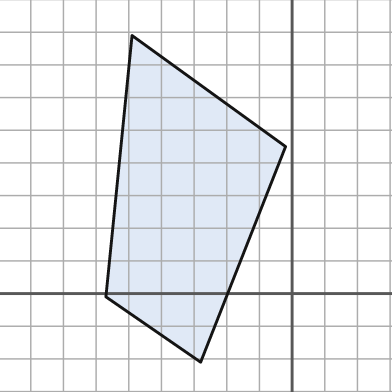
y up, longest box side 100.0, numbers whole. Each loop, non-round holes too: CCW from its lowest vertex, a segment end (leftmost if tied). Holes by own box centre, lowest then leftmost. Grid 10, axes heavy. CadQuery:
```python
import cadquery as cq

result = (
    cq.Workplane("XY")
    .moveTo(-28.0, -21.0)
    .lineTo(-2.0, 45.0)
    .lineTo(-49.0, 79.0)
    .lineTo(-57.0, -1.0)
    .close()
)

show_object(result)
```